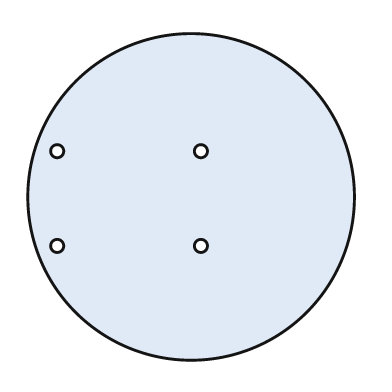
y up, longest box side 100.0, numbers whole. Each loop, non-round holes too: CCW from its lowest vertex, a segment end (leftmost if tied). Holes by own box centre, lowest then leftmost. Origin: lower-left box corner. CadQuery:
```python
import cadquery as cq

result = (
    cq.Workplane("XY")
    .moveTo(50.0, 50.0)
    .circle(50.0)
    .moveTo(9.0, 35.0)
    .circle(2.0)
    .moveTo(53.0, 35.0)
    .circle(2.0)
    .moveTo(9.0, 64.0)
    .circle(2.0)
    .moveTo(53.0, 64.0)
    .circle(2.0)
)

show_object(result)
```